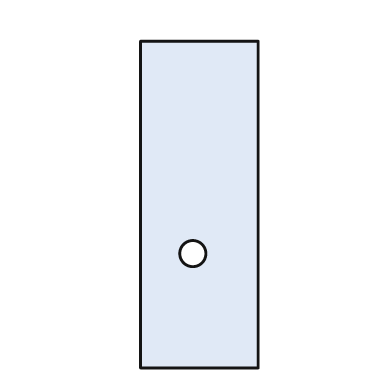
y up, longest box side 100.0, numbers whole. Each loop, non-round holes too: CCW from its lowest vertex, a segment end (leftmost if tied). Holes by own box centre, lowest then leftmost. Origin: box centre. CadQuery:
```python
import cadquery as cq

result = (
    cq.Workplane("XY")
    .moveTo(-18.0, -50.0)
    .lineTo(18.0, -50.0)
    .lineTo(18.0, 50.0)
    .lineTo(-18.0, 50.0)
    .close()
    .moveTo(-2.0, -15.0)
    .circle(4.0)
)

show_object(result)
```